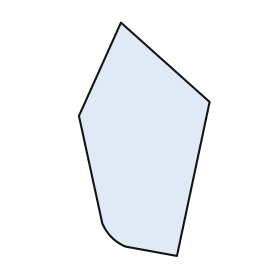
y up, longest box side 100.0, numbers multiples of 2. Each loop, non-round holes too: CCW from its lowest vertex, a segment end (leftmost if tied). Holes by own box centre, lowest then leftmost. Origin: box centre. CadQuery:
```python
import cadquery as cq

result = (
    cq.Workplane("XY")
    .moveTo(14.0, -50.0)
    .lineTo(28.0, 16.0)
    .lineTo(-10.0, 50.0)
    .lineTo(-28.0, 10.0)
    .lineTo(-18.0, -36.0)
    .threePointArc((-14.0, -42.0), (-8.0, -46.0))
    .close()
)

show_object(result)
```